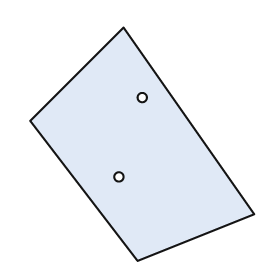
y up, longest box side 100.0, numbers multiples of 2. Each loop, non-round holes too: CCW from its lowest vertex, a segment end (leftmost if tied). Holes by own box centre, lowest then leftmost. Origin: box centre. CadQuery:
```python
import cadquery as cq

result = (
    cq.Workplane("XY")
    .moveTo(-2.0, -50.0)
    .lineTo(48.0, -30.0)
    .lineTo(-8.0, 50.0)
    .lineTo(-48.0, 10.0)
    .close()
    .moveTo(-10.0, -14.0)
    .circle(2.0)
    .moveTo(0.0, 20.0)
    .circle(2.0)
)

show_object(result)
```